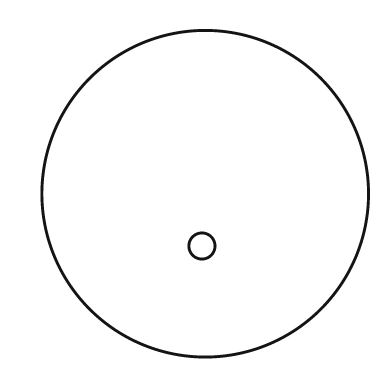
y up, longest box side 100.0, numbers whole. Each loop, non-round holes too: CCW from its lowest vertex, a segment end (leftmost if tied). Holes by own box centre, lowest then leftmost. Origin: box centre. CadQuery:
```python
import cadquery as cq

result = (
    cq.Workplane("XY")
    .moveTo(0.0, 0.0)
    .circle(50.0)
    .moveTo(-1.0, -16.0)
    .circle(4.0)
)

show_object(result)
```